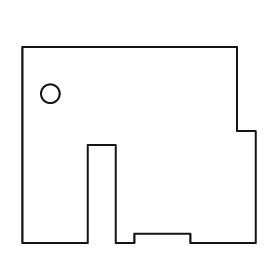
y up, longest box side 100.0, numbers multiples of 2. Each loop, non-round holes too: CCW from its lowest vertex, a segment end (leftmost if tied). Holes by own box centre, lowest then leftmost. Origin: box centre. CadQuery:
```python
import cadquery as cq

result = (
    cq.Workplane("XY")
    .moveTo(-50.0, -42.0)
    .lineTo(-22.0, -42.0)
    .lineTo(-22.0, 0.0)
    .lineTo(-10.0, 0.0)
    .lineTo(-10.0, -42.0)
    .lineTo(-2.0, -42.0)
    .lineTo(-2.0, -38.0)
    .lineTo(22.0, -38.0)
    .lineTo(22.0, -42.0)
    .lineTo(50.0, -42.0)
    .lineTo(50.0, 6.0)
    .lineTo(42.0, 6.0)
    .lineTo(42.0, 42.0)
    .lineTo(-50.0, 42.0)
    .close()
    .moveTo(-38.0, 22.0)
    .circle(4.0)
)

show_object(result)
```